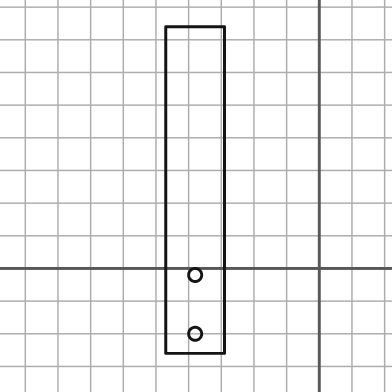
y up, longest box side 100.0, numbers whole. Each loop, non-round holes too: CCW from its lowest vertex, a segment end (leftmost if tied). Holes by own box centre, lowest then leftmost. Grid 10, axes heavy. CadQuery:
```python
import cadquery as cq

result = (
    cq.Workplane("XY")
    .moveTo(-47.0, -26.0)
    .lineTo(-29.0, -26.0)
    .lineTo(-29.0, 74.0)
    .lineTo(-47.0, 74.0)
    .close()
    .moveTo(-38.0, -20.0)
    .circle(2.0)
    .moveTo(-38.0, -2.0)
    .circle(2.0)
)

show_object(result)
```